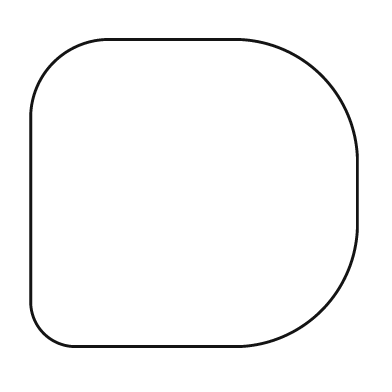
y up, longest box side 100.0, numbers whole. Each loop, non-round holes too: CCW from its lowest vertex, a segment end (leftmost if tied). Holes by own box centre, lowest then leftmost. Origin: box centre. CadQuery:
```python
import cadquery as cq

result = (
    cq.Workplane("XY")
    .moveTo(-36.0, -47.0)
    .lineTo(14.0, -47.0)
    .threePointArc((39.0, -36.0), (50.0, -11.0))
    .lineTo(50.0, 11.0)
    .threePointArc((39.0, 36.0), (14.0, 47.0))
    .lineTo(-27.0, 47.0)
    .threePointArc((-43.0, 40.0), (-50.0, 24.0))
    .lineTo(-50.0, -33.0)
    .threePointArc((-46.0, -43.0), (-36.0, -47.0))
    .close()
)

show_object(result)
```